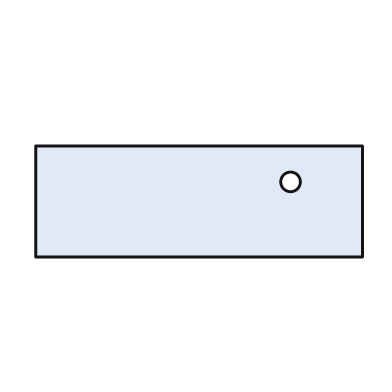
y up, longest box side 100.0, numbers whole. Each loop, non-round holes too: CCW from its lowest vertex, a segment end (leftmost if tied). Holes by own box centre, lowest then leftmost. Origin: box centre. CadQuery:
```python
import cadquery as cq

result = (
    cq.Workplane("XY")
    .moveTo(-50.0, -17.0)
    .lineTo(50.0, -17.0)
    .lineTo(50.0, 17.0)
    .lineTo(-50.0, 17.0)
    .close()
    .moveTo(28.0, 6.0)
    .circle(3.0)
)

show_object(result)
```